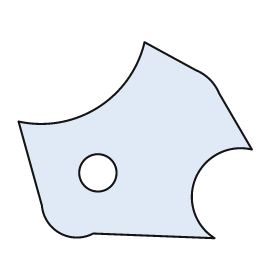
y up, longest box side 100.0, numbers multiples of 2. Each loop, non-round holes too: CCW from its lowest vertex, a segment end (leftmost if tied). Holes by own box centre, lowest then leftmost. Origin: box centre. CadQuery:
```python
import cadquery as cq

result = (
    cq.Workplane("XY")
    .moveTo(34.0, -42.0)
    .threePointArc((26.0, -16.0), (50.0, -4.0))
    .lineTo(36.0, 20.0)
    .threePointArc((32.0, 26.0), (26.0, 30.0))
    .lineTo(4.0, 42.0)
    .threePointArc((-16.0, 14.0), (-50.0, 8.0))
    .lineTo(-40.0, -28.0)
    .threePointArc((-32.0, -40.0), (-18.0, -40.0))
    .close()
    .moveTo(-16.0, -14.0)
    .circle(8.0)
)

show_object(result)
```